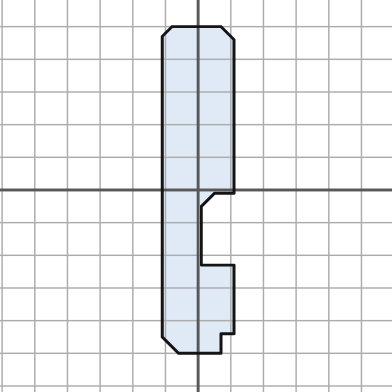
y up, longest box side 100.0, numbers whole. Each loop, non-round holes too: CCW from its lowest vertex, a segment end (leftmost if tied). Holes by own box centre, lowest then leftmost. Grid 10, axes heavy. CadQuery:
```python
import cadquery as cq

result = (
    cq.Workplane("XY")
    .moveTo(-6.0, -50.0)
    .lineTo(7.0, -50.0)
    .lineTo(7.0, -44.0)
    .lineTo(11.0, -44.0)
    .lineTo(11.0, -23.0)
    .lineTo(1.0, -23.0)
    .lineTo(1.0, -5.0)
    .lineTo(5.0, -1.0)
    .lineTo(11.0, -1.0)
    .lineTo(11.0, 46.0)
    .lineTo(7.0, 50.0)
    .lineTo(-8.0, 50.0)
    .lineTo(-11.0, 47.0)
    .lineTo(-11.0, -45.0)
    .close()
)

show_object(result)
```